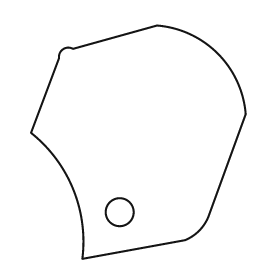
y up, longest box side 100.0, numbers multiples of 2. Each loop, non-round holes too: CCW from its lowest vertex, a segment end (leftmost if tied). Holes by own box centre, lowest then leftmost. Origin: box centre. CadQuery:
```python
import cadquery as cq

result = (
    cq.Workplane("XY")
    .moveTo(-24.0, -50.0)
    .lineTo(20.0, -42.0)
    .threePointArc((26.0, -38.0), (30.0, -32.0))
    .lineTo(46.0, 12.0)
    .threePointArc((34.0, 38.0), (8.0, 50.0))
    .lineTo(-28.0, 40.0)
    .threePointArc((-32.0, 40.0), (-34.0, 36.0))
    .lineTo(-46.0, 4.0)
    .threePointArc((-28.0, -20.0), (-24.0, -50.0))
    .close()
    .moveTo(-8.0, -30.0)
    .circle(6.0)
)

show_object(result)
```